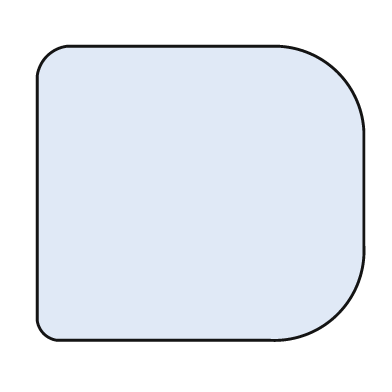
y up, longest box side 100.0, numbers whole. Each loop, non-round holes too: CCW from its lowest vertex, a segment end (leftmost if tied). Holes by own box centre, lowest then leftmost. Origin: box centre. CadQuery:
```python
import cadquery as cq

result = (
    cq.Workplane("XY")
    .moveTo(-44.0, -45.0)
    .lineTo(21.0, -45.0)
    .threePointArc((42.0, -37.0), (50.0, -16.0))
    .lineTo(50.0, 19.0)
    .threePointArc((42.0, 37.0), (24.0, 45.0))
    .lineTo(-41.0, 45.0)
    .threePointArc((-47.0, 42.0), (-50.0, 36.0))
    .lineTo(-50.0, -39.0)
    .threePointArc((-48.0, -43.0), (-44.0, -45.0))
    .close()
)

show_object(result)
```